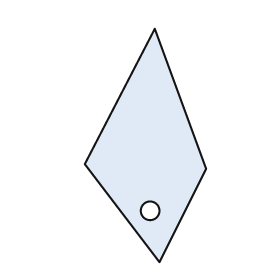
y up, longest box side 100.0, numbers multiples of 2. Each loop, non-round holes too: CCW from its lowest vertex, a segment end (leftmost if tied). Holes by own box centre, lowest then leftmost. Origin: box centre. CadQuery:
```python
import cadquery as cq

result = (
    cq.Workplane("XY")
    .moveTo(6.0, -50.0)
    .lineTo(26.0, -10.0)
    .lineTo(4.0, 50.0)
    .lineTo(-26.0, -8.0)
    .close()
    .moveTo(2.0, -28.0)
    .circle(4.0)
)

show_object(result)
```